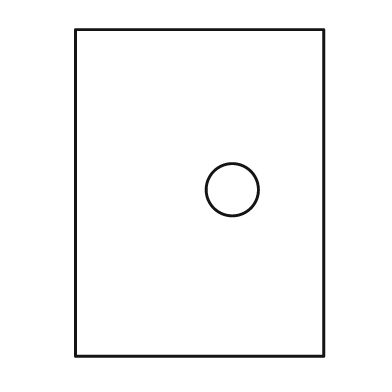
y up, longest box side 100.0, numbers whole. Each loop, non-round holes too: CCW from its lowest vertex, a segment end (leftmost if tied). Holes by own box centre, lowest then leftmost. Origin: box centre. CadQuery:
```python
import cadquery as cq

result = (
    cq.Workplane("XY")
    .moveTo(-38.0, -50.0)
    .lineTo(38.0, -50.0)
    .lineTo(38.0, 50.0)
    .lineTo(-38.0, 50.0)
    .close()
    .moveTo(10.0, 1.0)
    .circle(8.0)
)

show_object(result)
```